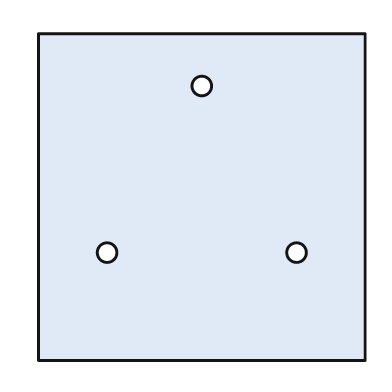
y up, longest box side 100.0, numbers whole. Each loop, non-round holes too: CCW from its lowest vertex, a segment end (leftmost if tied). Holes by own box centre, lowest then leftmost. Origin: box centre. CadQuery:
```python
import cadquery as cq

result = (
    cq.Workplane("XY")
    .moveTo(-50.0, -50.0)
    .lineTo(50.0, -50.0)
    .lineTo(50.0, 50.0)
    .lineTo(-50.0, 50.0)
    .close()
    .moveTo(-29.0, -17.0)
    .circle(3.0)
    .moveTo(29.0, -17.0)
    .circle(3.0)
    .moveTo(0.0, 34.0)
    .circle(3.0)
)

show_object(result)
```